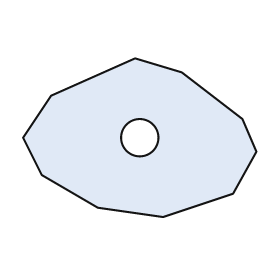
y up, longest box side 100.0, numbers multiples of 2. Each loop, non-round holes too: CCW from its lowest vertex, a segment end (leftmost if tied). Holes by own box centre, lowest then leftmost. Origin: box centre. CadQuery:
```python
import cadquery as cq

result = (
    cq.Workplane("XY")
    .moveTo(10.0, -34.0)
    .lineTo(40.0, -24.0)
    .lineTo(50.0, -6.0)
    .lineTo(44.0, 8.0)
    .lineTo(18.0, 28.0)
    .lineTo(-2.0, 34.0)
    .lineTo(-38.0, 18.0)
    .lineTo(-50.0, 0.0)
    .lineTo(-42.0, -16.0)
    .lineTo(-18.0, -30.0)
    .close()
    .moveTo(0.0, 0.0)
    .circle(8.0)
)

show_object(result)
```